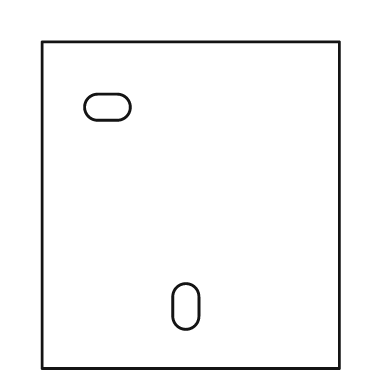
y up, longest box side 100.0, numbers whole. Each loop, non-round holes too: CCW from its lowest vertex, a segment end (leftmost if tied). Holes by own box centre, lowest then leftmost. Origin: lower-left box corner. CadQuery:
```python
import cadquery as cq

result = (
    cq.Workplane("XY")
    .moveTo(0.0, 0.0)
    .lineTo(91.0, 0.0)
    .lineTo(91.0, 100.0)
    .lineTo(0.0, 100.0)
    .close()
    .moveTo(40.0, 16.0)
    .threePointArc((44.0, 12.0), (48.0, 16.0))
    .lineTo(48.0, 22.0)
    .threePointArc((44.0, 26.0), (40.0, 22.0))
    .close()
    .moveTo(17.0, 76.0)
    .lineTo(23.0, 76.0)
    .threePointArc((27.0, 80.0), (23.0, 84.0))
    .lineTo(17.0, 84.0)
    .threePointArc((13.0, 80.0), (17.0, 76.0))
    .close()
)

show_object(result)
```